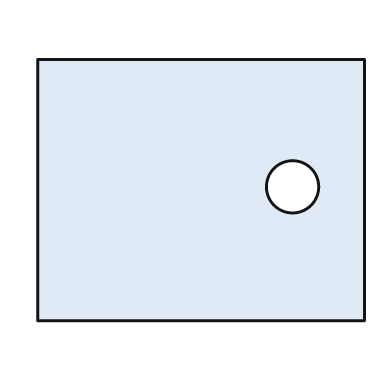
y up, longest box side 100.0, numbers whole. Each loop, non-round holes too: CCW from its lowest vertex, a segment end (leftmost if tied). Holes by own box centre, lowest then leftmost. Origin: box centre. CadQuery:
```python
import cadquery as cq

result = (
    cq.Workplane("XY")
    .moveTo(-50.0, -40.0)
    .lineTo(50.0, -40.0)
    .lineTo(50.0, 40.0)
    .lineTo(-50.0, 40.0)
    .close()
    .moveTo(28.0, 1.0)
    .circle(8.0)
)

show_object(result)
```